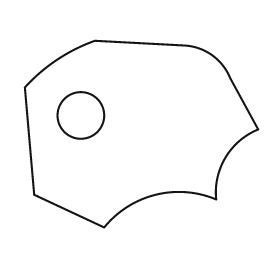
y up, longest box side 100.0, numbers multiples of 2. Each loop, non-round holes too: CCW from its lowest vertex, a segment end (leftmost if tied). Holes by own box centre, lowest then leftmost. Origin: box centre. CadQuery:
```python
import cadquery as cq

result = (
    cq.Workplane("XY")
    .moveTo(-16.0, -40.0)
    .threePointArc((6.0, -26.0), (32.0, -28.0))
    .threePointArc((36.0, -10.0), (50.0, 2.0))
    .lineTo(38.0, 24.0)
    .threePointArc((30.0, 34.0), (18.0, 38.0))
    .lineTo(-20.0, 40.0)
    .threePointArc((-36.0, 32.0), (-50.0, 20.0))
    .lineTo(-46.0, -26.0)
    .close()
    .moveTo(-26.0, 8.0)
    .circle(10.0)
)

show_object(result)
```